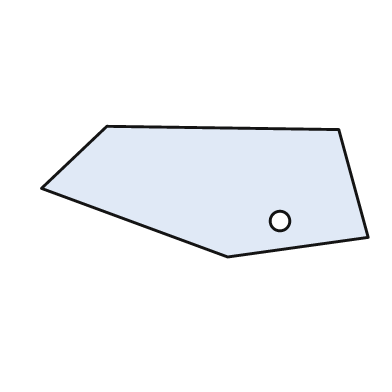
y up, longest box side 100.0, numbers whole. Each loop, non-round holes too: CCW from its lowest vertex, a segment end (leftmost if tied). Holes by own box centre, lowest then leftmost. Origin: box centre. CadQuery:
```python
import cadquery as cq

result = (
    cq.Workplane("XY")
    .moveTo(7.0, -20.0)
    .lineTo(50.0, -14.0)
    .lineTo(41.0, 19.0)
    .lineTo(-30.0, 20.0)
    .lineTo(-50.0, 1.0)
    .close()
    .moveTo(23.0, -9.0)
    .circle(3.0)
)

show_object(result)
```